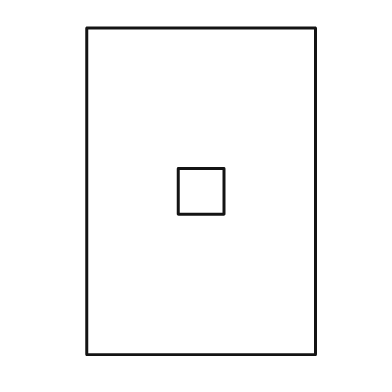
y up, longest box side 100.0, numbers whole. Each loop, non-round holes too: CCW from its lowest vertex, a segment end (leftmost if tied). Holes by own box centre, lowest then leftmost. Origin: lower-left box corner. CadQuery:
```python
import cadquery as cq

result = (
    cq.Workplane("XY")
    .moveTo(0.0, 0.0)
    .lineTo(70.0, 0.0)
    .lineTo(70.0, 100.0)
    .lineTo(0.0, 100.0)
    .close()
    .moveTo(28.0, 43.0)
    .lineTo(42.0, 43.0)
    .lineTo(42.0, 57.0)
    .lineTo(28.0, 57.0)
    .close()
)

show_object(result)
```